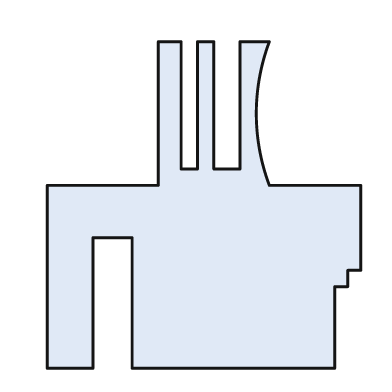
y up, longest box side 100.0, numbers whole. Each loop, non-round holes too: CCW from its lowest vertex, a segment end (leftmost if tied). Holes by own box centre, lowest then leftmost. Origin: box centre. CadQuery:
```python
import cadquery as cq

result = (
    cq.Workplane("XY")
    .moveTo(-48.0, -50.0)
    .lineTo(-34.0, -50.0)
    .lineTo(-34.0, -10.0)
    .lineTo(-22.0, -10.0)
    .lineTo(-22.0, -50.0)
    .lineTo(40.0, -50.0)
    .lineTo(40.0, -25.0)
    .lineTo(44.0, -25.0)
    .lineTo(44.0, -20.0)
    .lineTo(48.0, -20.0)
    .lineTo(48.0, 6.0)
    .lineTo(20.0, 6.0)
    .threePointArc((16.0, 28.0), (20.0, 50.0))
    .lineTo(11.0, 50.0)
    .lineTo(11.0, 11.0)
    .lineTo(3.0, 11.0)
    .lineTo(3.0, 50.0)
    .lineTo(-2.0, 50.0)
    .lineTo(-2.0, 11.0)
    .lineTo(-7.0, 11.0)
    .lineTo(-7.0, 50.0)
    .lineTo(-14.0, 50.0)
    .lineTo(-14.0, 6.0)
    .lineTo(-48.0, 6.0)
    .close()
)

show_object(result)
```